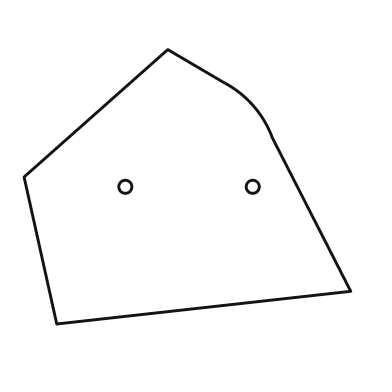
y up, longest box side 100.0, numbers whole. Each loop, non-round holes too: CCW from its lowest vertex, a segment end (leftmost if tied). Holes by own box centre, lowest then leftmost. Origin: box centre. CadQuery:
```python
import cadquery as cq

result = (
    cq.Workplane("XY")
    .moveTo(-40.0, -42.0)
    .lineTo(50.0, -32.0)
    .lineTo(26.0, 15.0)
    .threePointArc((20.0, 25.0), (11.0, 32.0))
    .lineTo(-6.0, 42.0)
    .lineTo(-50.0, 3.0)
    .close()
    .moveTo(-19.0, 0.0)
    .circle(2.0)
    .moveTo(20.0, 0.0)
    .circle(2.0)
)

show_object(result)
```